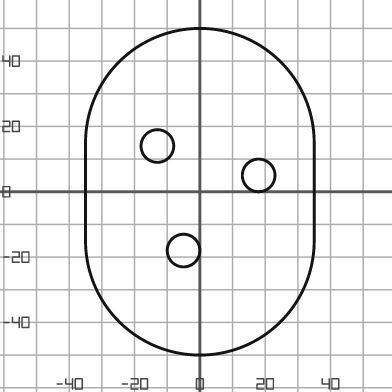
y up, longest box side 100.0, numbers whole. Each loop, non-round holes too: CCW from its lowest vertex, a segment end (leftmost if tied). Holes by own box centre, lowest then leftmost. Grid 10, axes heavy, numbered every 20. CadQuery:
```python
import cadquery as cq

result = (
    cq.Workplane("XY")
    .moveTo(-35.0, -15.0)
    .threePointArc((0.0, -50.0), (35.0, -15.0))
    .lineTo(35.0, 15.0)
    .threePointArc((0.0, 50.0), (-35.0, 15.0))
    .close()
    .moveTo(-5.0, -18.0)
    .circle(5.0)
    .moveTo(18.0, 5.0)
    .circle(5.0)
    .moveTo(-13.0, 14.0)
    .circle(5.0)
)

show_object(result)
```